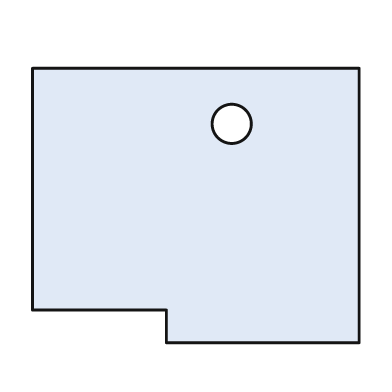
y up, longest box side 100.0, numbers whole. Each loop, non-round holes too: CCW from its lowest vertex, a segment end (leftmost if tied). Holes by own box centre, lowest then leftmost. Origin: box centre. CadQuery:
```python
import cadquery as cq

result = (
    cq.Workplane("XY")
    .moveTo(-9.0, -42.0)
    .lineTo(50.0, -42.0)
    .lineTo(50.0, 42.0)
    .lineTo(-50.0, 42.0)
    .lineTo(-50.0, -32.0)
    .lineTo(-9.0, -32.0)
    .close()
    .moveTo(11.0, 25.0)
    .circle(6.0)
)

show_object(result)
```